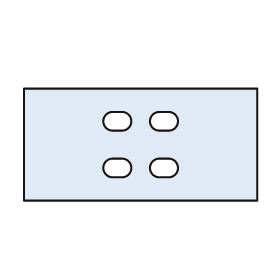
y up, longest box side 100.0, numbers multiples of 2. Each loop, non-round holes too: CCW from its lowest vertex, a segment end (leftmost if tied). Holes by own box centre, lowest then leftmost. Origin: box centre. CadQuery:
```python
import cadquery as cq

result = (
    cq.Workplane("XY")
    .moveTo(-50.0, -24.0)
    .lineTo(50.0, -24.0)
    .lineTo(50.0, 24.0)
    .lineTo(-50.0, 24.0)
    .close()
    .moveTo(-12.0, -14.0)
    .lineTo(-8.0, -14.0)
    .threePointArc((-4.0, -10.0), (-8.0, -6.0))
    .lineTo(-12.0, -6.0)
    .threePointArc((-16.0, -10.0), (-12.0, -14.0))
    .close()
    .moveTo(8.0, -14.0)
    .lineTo(12.0, -14.0)
    .threePointArc((16.0, -10.0), (12.0, -6.0))
    .lineTo(8.0, -6.0)
    .threePointArc((4.0, -10.0), (8.0, -14.0))
    .close()
    .moveTo(-12.0, 6.0)
    .lineTo(-8.0, 6.0)
    .threePointArc((-4.0, 10.0), (-8.0, 14.0))
    .lineTo(-12.0, 14.0)
    .threePointArc((-16.0, 10.0), (-12.0, 6.0))
    .close()
    .moveTo(8.0, 6.0)
    .lineTo(12.0, 6.0)
    .threePointArc((16.0, 10.0), (12.0, 14.0))
    .lineTo(8.0, 14.0)
    .threePointArc((4.0, 10.0), (8.0, 6.0))
    .close()
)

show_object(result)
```